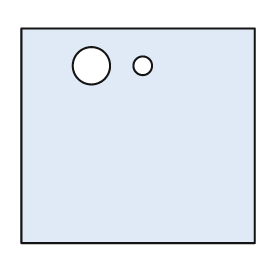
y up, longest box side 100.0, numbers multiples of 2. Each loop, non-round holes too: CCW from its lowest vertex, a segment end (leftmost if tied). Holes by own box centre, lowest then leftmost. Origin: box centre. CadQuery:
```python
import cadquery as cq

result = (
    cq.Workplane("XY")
    .moveTo(-50.0, -46.0)
    .lineTo(50.0, -46.0)
    .lineTo(50.0, 46.0)
    .lineTo(-50.0, 46.0)
    .close()
    .moveTo(-20.0, 30.0)
    .circle(8.0)
    .moveTo(2.0, 30.0)
    .circle(4.0)
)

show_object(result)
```